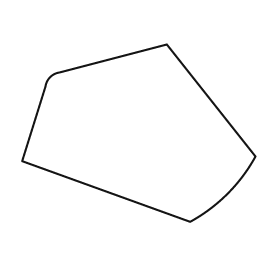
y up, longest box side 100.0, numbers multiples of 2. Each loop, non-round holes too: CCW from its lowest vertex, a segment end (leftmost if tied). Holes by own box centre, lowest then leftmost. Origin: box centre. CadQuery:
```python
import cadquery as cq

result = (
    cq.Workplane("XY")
    .moveTo(22.0, -38.0)
    .threePointArc((38.0, -26.0), (50.0, -10.0))
    .lineTo(12.0, 38.0)
    .lineTo(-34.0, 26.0)
    .threePointArc((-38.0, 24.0), (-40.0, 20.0))
    .lineTo(-50.0, -12.0)
    .close()
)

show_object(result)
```